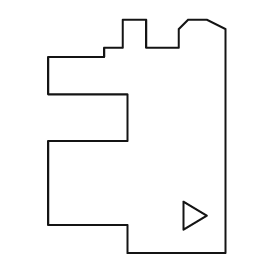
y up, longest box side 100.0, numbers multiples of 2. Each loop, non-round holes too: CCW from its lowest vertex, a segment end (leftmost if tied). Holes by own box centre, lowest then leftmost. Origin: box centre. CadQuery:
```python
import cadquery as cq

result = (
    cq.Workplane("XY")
    .moveTo(-4.0, -50.0)
    .lineTo(38.0, -50.0)
    .lineTo(38.0, 46.0)
    .lineTo(30.0, 50.0)
    .lineTo(22.0, 50.0)
    .lineTo(18.0, 46.0)
    .lineTo(18.0, 38.0)
    .lineTo(4.0, 38.0)
    .lineTo(4.0, 50.0)
    .lineTo(-6.0, 50.0)
    .lineTo(-6.0, 38.0)
    .lineTo(-14.0, 38.0)
    .lineTo(-14.0, 34.0)
    .lineTo(-38.0, 34.0)
    .lineTo(-38.0, 18.0)
    .lineTo(-4.0, 18.0)
    .lineTo(-4.0, -2.0)
    .lineTo(-38.0, -2.0)
    .lineTo(-38.0, -38.0)
    .lineTo(-4.0, -38.0)
    .close()
    .moveTo(20.0, -40.0)
    .lineTo(30.0, -34.0)
    .lineTo(20.0, -28.0)
    .close()
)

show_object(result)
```